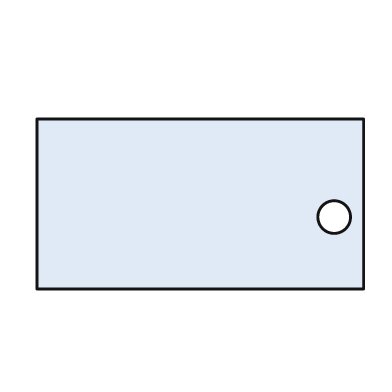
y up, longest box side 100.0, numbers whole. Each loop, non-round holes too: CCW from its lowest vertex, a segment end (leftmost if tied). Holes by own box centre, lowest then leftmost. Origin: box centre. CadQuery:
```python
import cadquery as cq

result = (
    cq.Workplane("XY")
    .moveTo(-50.0, -26.0)
    .lineTo(50.0, -26.0)
    .lineTo(50.0, 26.0)
    .lineTo(-50.0, 26.0)
    .close()
    .moveTo(41.0, -4.0)
    .circle(5.0)
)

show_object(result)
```